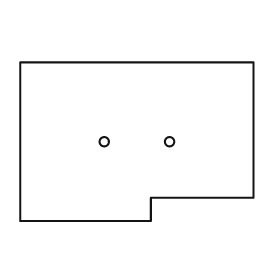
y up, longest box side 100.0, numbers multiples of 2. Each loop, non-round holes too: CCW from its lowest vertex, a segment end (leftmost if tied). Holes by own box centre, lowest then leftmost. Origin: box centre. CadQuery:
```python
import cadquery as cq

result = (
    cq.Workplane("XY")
    .moveTo(-50.0, -34.0)
    .lineTo(6.0, -34.0)
    .lineTo(6.0, -24.0)
    .lineTo(50.0, -24.0)
    .lineTo(50.0, 34.0)
    .lineTo(-50.0, 34.0)
    .close()
    .moveTo(-14.0, 0.0)
    .circle(2.0)
    .moveTo(14.0, 0.0)
    .circle(2.0)
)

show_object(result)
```